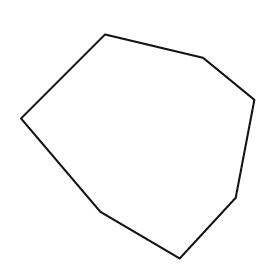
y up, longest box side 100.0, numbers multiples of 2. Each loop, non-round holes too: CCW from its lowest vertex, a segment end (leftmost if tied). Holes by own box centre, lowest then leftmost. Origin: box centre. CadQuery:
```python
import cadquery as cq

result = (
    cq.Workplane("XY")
    .moveTo(18.0, -48.0)
    .lineTo(42.0, -22.0)
    .lineTo(50.0, 20.0)
    .lineTo(28.0, 38.0)
    .lineTo(-14.0, 48.0)
    .lineTo(-50.0, 12.0)
    .lineTo(-16.0, -28.0)
    .close()
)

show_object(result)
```